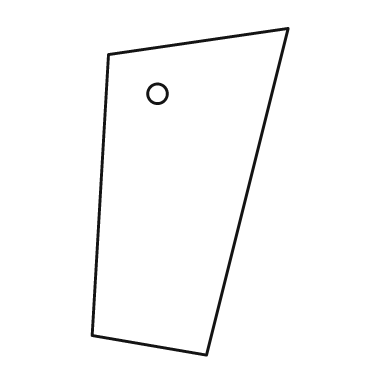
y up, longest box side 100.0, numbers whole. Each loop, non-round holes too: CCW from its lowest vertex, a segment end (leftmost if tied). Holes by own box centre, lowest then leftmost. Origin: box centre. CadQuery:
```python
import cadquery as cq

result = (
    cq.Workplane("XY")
    .moveTo(5.0, -50.0)
    .lineTo(30.0, 50.0)
    .lineTo(-25.0, 42.0)
    .lineTo(-30.0, -44.0)
    .close()
    .moveTo(-10.0, 30.0)
    .circle(3.0)
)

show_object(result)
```